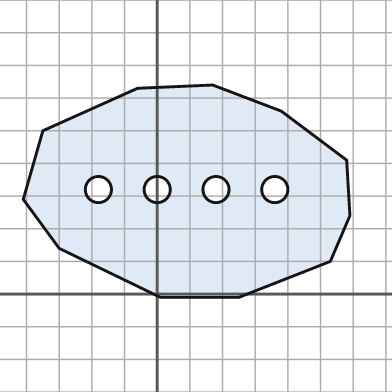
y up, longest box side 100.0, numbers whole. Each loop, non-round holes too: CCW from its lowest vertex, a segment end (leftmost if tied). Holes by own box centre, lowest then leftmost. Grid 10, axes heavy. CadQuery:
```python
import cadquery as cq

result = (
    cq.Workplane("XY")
    .moveTo(1.0, -1.0)
    .lineTo(25.0, -1.0)
    .lineTo(53.0, 10.0)
    .lineTo(59.0, 24.0)
    .lineTo(58.0, 41.0)
    .lineTo(38.0, 56.0)
    .lineTo(17.0, 64.0)
    .lineTo(-6.0, 63.0)
    .lineTo(-35.0, 50.0)
    .lineTo(-41.0, 29.0)
    .lineTo(-30.0, 14.0)
    .close()
    .moveTo(-18.0, 32.0)
    .circle(4.0)
    .moveTo(0.0, 32.0)
    .circle(4.0)
    .moveTo(18.0, 32.0)
    .circle(4.0)
    .moveTo(36.0, 32.0)
    .circle(4.0)
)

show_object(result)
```